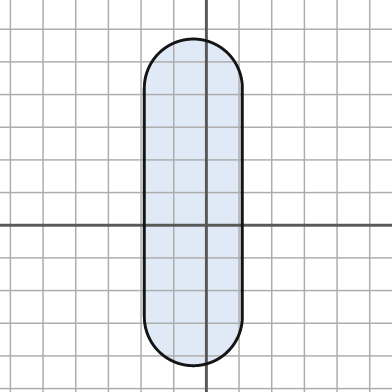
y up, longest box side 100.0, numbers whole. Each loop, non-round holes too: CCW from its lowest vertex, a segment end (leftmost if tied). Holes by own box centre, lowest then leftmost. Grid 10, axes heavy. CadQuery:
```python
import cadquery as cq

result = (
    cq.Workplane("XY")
    .moveTo(-19.0, -28.0)
    .threePointArc((-4.0, -43.0), (11.0, -28.0))
    .lineTo(11.0, 42.0)
    .threePointArc((-4.0, 57.0), (-19.0, 42.0))
    .close()
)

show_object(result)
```